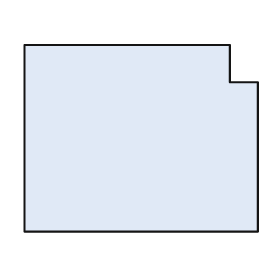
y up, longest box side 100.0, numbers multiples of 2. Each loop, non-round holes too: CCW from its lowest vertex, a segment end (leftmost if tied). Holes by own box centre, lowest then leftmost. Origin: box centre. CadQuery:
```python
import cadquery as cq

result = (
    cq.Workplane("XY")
    .moveTo(-50.0, -40.0)
    .lineTo(50.0, -40.0)
    .lineTo(50.0, 24.0)
    .lineTo(38.0, 24.0)
    .lineTo(38.0, 40.0)
    .lineTo(-50.0, 40.0)
    .close()
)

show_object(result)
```